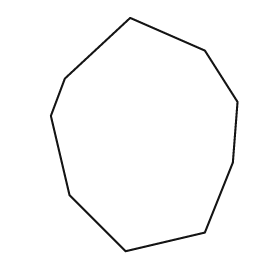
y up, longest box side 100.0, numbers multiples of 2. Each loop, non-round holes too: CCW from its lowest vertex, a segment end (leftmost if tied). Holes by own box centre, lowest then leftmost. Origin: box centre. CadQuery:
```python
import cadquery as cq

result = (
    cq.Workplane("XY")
    .moveTo(-8.0, -50.0)
    .lineTo(26.0, -42.0)
    .lineTo(38.0, -12.0)
    .lineTo(40.0, 14.0)
    .lineTo(26.0, 36.0)
    .lineTo(-6.0, 50.0)
    .lineTo(-34.0, 24.0)
    .lineTo(-40.0, 8.0)
    .lineTo(-32.0, -26.0)
    .close()
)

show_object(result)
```